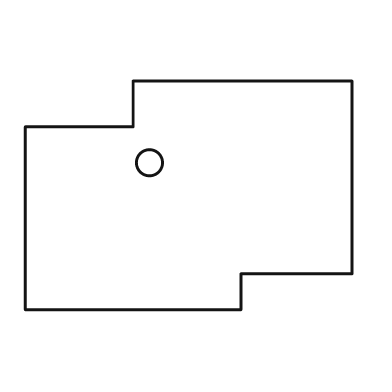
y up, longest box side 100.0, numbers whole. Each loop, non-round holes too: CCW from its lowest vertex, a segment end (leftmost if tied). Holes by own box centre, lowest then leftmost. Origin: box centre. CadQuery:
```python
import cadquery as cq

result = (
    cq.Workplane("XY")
    .moveTo(-50.0, -35.0)
    .lineTo(16.0, -35.0)
    .lineTo(16.0, -24.0)
    .lineTo(50.0, -24.0)
    .lineTo(50.0, 35.0)
    .lineTo(-17.0, 35.0)
    .lineTo(-17.0, 21.0)
    .lineTo(-50.0, 21.0)
    .close()
    .moveTo(-12.0, 10.0)
    .circle(4.0)
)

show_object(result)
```